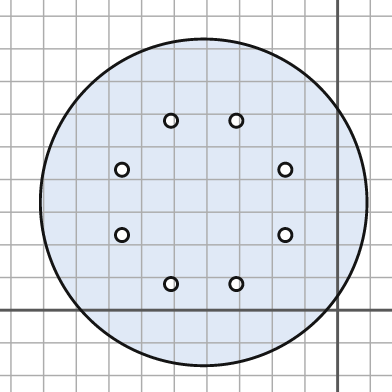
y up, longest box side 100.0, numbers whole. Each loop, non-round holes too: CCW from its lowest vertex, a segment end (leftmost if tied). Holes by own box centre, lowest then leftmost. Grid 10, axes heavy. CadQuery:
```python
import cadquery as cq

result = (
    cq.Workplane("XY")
    .moveTo(-41.0, 33.0)
    .circle(50.0)
    .moveTo(-51.0, 8.0)
    .circle(2.0)
    .moveTo(-31.0, 8.0)
    .circle(2.0)
    .moveTo(-66.0, 23.0)
    .circle(2.0)
    .moveTo(-16.0, 23.0)
    .circle(2.0)
    .moveTo(-66.0, 43.0)
    .circle(2.0)
    .moveTo(-16.0, 43.0)
    .circle(2.0)
    .moveTo(-51.0, 58.0)
    .circle(2.0)
    .moveTo(-31.0, 58.0)
    .circle(2.0)
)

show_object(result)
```